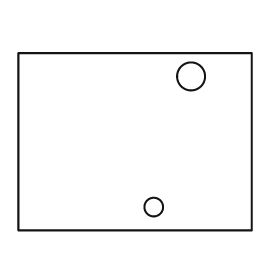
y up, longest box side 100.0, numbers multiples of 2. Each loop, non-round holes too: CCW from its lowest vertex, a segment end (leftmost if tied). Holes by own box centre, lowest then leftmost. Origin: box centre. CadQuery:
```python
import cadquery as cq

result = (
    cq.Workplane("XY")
    .moveTo(-50.0, -38.0)
    .lineTo(50.0, -38.0)
    .lineTo(50.0, 38.0)
    .lineTo(-50.0, 38.0)
    .close()
    .moveTo(8.0, -28.0)
    .circle(4.0)
    .moveTo(24.0, 28.0)
    .circle(6.0)
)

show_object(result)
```